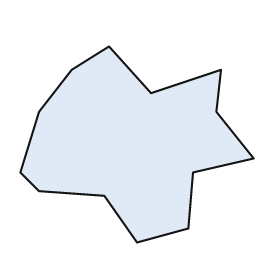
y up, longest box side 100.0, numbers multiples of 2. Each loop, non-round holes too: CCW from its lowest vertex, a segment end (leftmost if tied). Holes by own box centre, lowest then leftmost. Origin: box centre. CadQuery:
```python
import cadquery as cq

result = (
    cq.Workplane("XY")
    .moveTo(0.0, -42.0)
    .lineTo(22.0, -36.0)
    .lineTo(24.0, -12.0)
    .lineTo(50.0, -6.0)
    .lineTo(34.0, 14.0)
    .lineTo(36.0, 32.0)
    .lineTo(6.0, 22.0)
    .lineTo(-12.0, 42.0)
    .lineTo(-28.0, 32.0)
    .lineTo(-42.0, 14.0)
    .lineTo(-50.0, -12.0)
    .lineTo(-42.0, -20.0)
    .lineTo(-14.0, -22.0)
    .close()
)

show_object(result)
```